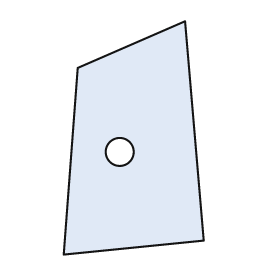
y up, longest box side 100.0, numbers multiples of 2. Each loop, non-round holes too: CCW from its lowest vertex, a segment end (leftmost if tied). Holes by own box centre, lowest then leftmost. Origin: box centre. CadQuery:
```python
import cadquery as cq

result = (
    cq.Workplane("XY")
    .moveTo(-30.0, -50.0)
    .lineTo(30.0, -44.0)
    .lineTo(22.0, 50.0)
    .lineTo(-24.0, 30.0)
    .close()
    .moveTo(-6.0, -6.0)
    .circle(6.0)
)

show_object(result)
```